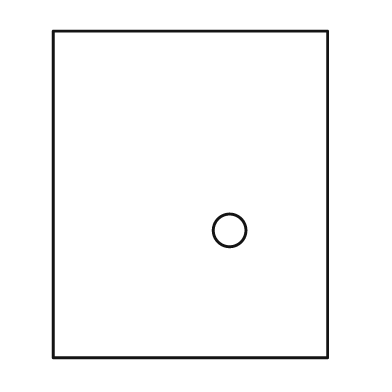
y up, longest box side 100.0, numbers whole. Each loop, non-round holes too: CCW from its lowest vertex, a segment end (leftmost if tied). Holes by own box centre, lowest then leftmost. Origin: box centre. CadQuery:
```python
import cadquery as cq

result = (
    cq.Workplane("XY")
    .moveTo(-42.0, -50.0)
    .lineTo(42.0, -50.0)
    .lineTo(42.0, 50.0)
    .lineTo(-42.0, 50.0)
    .close()
    .moveTo(12.0, -11.0)
    .circle(5.0)
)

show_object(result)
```